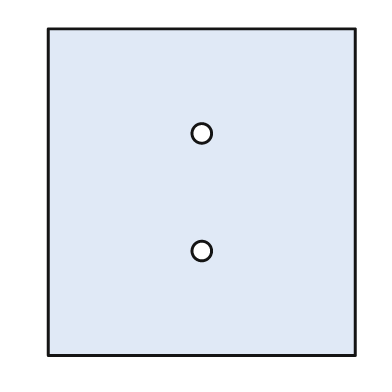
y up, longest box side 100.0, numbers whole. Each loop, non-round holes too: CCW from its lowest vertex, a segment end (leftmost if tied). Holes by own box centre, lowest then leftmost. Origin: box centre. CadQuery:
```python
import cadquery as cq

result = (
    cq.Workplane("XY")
    .moveTo(-47.0, -50.0)
    .lineTo(47.0, -50.0)
    .lineTo(47.0, 50.0)
    .lineTo(-47.0, 50.0)
    .close()
    .moveTo(0.0, -18.0)
    .circle(3.0)
    .moveTo(0.0, 18.0)
    .circle(3.0)
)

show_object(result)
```